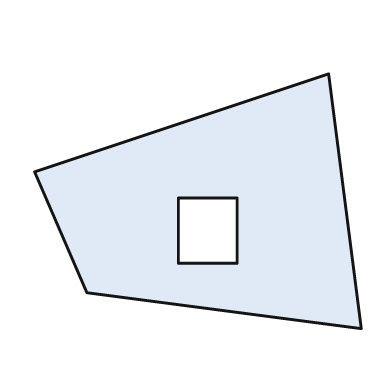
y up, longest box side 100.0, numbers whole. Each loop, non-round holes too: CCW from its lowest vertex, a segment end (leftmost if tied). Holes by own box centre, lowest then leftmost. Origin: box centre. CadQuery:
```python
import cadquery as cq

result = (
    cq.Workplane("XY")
    .moveTo(50.0, -39.0)
    .lineTo(40.0, 39.0)
    .lineTo(-50.0, 9.0)
    .lineTo(-34.0, -28.0)
    .close()
    .moveTo(-6.0, -19.0)
    .lineTo(12.0, -19.0)
    .lineTo(12.0, 1.0)
    .lineTo(-6.0, 1.0)
    .close()
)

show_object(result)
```